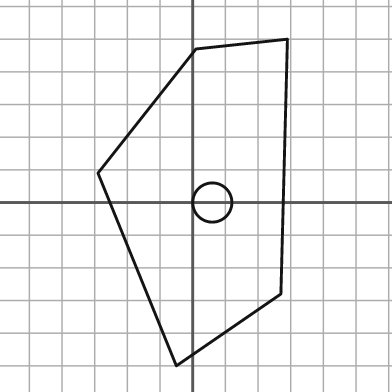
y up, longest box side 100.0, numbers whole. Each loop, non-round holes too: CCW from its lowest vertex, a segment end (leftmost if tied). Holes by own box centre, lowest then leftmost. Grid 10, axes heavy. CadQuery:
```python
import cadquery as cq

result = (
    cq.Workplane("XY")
    .moveTo(-5.0, -50.0)
    .lineTo(27.0, -28.0)
    .lineTo(29.0, 50.0)
    .lineTo(1.0, 47.0)
    .lineTo(-29.0, 9.0)
    .close()
    .moveTo(6.0, 0.0)
    .circle(6.0)
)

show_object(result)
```